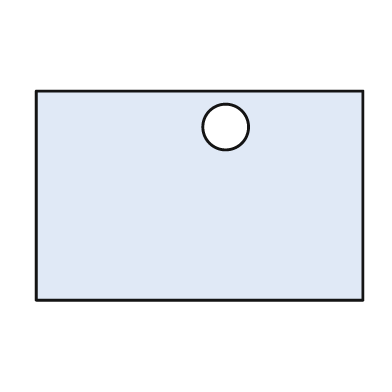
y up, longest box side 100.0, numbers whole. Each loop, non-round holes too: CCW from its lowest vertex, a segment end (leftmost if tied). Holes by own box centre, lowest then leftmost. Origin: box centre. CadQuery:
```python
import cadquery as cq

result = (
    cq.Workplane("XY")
    .moveTo(-50.0, -32.0)
    .lineTo(50.0, -32.0)
    .lineTo(50.0, 32.0)
    .lineTo(-50.0, 32.0)
    .close()
    .moveTo(8.0, 21.0)
    .circle(7.0)
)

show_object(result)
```